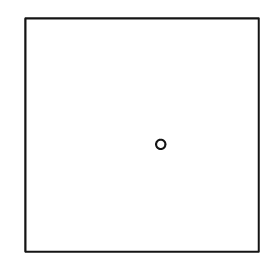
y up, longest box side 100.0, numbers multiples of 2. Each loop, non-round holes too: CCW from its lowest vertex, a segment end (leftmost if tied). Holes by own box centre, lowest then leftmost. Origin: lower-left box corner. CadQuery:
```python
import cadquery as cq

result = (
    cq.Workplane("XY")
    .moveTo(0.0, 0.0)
    .lineTo(100.0, 0.0)
    .lineTo(100.0, 100.0)
    .lineTo(0.0, 100.0)
    .close()
    .moveTo(58.0, 46.0)
    .circle(2.0)
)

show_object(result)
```